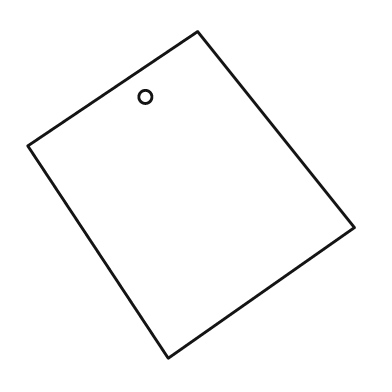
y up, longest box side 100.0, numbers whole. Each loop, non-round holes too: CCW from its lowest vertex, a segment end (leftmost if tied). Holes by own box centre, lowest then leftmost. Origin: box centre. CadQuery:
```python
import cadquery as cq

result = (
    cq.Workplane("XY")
    .moveTo(-7.0, -50.0)
    .lineTo(50.0, -10.0)
    .lineTo(2.0, 50.0)
    .lineTo(-50.0, 15.0)
    .close()
    .moveTo(-14.0, 30.0)
    .circle(2.0)
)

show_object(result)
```